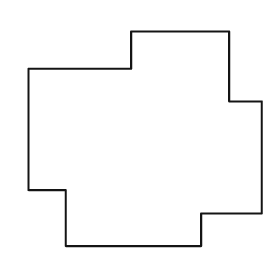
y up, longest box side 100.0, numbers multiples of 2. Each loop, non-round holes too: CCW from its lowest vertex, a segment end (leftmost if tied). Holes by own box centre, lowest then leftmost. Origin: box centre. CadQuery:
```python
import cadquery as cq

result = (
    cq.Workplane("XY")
    .moveTo(-34.0, -46.0)
    .lineTo(24.0, -46.0)
    .lineTo(24.0, -32.0)
    .lineTo(50.0, -32.0)
    .lineTo(50.0, 16.0)
    .lineTo(36.0, 16.0)
    .lineTo(36.0, 46.0)
    .lineTo(-6.0, 46.0)
    .lineTo(-6.0, 30.0)
    .lineTo(-50.0, 30.0)
    .lineTo(-50.0, -22.0)
    .lineTo(-34.0, -22.0)
    .close()
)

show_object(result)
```